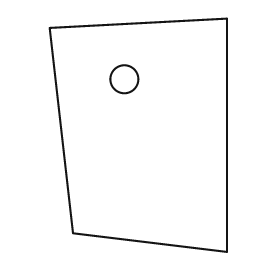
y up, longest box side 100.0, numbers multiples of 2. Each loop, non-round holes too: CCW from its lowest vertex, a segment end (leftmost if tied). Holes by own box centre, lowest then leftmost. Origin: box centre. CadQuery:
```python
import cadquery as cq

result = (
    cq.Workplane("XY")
    .moveTo(38.0, -50.0)
    .lineTo(38.0, 50.0)
    .lineTo(-38.0, 46.0)
    .lineTo(-28.0, -42.0)
    .close()
    .moveTo(-6.0, 24.0)
    .circle(6.0)
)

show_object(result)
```